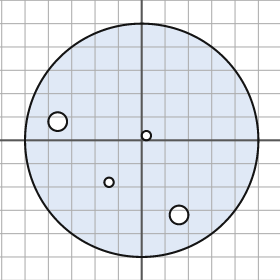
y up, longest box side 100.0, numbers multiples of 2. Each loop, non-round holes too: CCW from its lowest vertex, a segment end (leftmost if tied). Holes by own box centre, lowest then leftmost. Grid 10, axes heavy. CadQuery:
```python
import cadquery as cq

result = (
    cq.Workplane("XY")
    .moveTo(0.0, 0.0)
    .circle(50.0)
    .moveTo(16.0, -32.0)
    .circle(4.0)
    .moveTo(-14.0, -18.0)
    .circle(2.0)
    .moveTo(2.0, 2.0)
    .circle(2.0)
    .moveTo(-36.0, 8.0)
    .circle(4.0)
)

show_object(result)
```